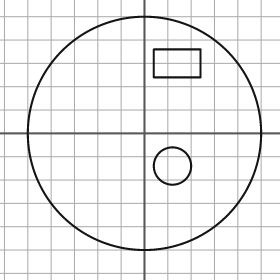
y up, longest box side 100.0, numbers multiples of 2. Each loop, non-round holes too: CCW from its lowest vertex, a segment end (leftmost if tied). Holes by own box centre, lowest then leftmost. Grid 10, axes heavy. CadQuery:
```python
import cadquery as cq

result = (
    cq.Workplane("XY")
    .moveTo(0.0, 0.0)
    .circle(50.0)
    .moveTo(12.0, -14.0)
    .circle(8.0)
    .moveTo(4.0, 24.0)
    .lineTo(24.0, 24.0)
    .lineTo(24.0, 36.0)
    .lineTo(4.0, 36.0)
    .close()
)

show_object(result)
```